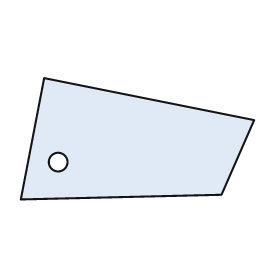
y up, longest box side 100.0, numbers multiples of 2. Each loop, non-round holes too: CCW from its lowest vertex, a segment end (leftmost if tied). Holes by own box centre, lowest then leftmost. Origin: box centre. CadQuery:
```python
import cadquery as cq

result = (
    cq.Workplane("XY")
    .moveTo(-50.0, -26.0)
    .lineTo(36.0, -24.0)
    .lineTo(50.0, 8.0)
    .lineTo(-40.0, 26.0)
    .close()
    .moveTo(-34.0, -10.0)
    .circle(4.0)
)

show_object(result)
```